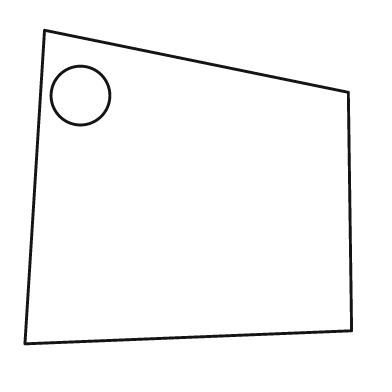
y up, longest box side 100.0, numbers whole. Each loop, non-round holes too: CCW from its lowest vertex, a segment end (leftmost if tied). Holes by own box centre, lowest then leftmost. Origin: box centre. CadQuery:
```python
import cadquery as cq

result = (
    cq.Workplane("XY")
    .moveTo(-50.0, -48.0)
    .lineTo(50.0, -44.0)
    .lineTo(49.0, 29.0)
    .lineTo(-44.0, 48.0)
    .close()
    .moveTo(-33.0, 28.0)
    .circle(9.0)
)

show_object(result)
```